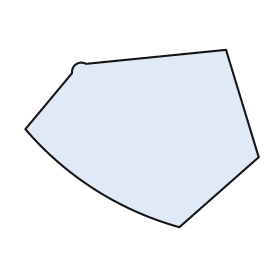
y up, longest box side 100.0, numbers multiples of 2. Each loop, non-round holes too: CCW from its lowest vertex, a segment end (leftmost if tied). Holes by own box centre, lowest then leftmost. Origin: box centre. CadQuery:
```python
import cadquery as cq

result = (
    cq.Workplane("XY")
    .moveTo(16.0, -38.0)
    .lineTo(50.0, -8.0)
    .lineTo(36.0, 38.0)
    .lineTo(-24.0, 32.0)
    .threePointArc((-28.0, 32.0), (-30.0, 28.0))
    .lineTo(-50.0, 4.0)
    .threePointArc((-20.0, -22.0), (16.0, -38.0))
    .close()
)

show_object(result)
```